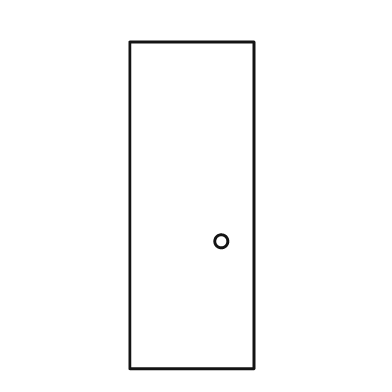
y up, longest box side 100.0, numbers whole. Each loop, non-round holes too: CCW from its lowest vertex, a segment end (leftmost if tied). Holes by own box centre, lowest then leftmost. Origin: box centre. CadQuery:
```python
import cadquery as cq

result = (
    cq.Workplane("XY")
    .moveTo(-19.0, -50.0)
    .lineTo(19.0, -50.0)
    .lineTo(19.0, 50.0)
    .lineTo(-19.0, 50.0)
    .close()
    .moveTo(9.0, -11.0)
    .circle(2.0)
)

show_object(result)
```